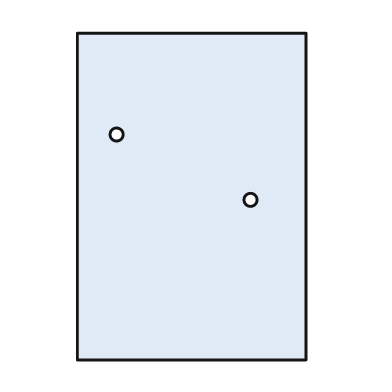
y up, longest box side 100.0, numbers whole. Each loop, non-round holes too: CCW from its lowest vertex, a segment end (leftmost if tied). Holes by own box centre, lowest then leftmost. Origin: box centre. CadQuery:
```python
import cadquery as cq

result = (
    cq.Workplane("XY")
    .moveTo(-35.0, -50.0)
    .lineTo(35.0, -50.0)
    .lineTo(35.0, 50.0)
    .lineTo(-35.0, 50.0)
    .close()
    .moveTo(18.0, -1.0)
    .circle(2.0)
    .moveTo(-23.0, 19.0)
    .circle(2.0)
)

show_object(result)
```